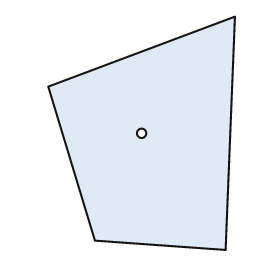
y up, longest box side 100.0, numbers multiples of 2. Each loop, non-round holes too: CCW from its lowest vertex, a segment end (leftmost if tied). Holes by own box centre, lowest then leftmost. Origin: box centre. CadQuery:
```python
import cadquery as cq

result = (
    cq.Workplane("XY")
    .moveTo(36.0, -50.0)
    .lineTo(40.0, 50.0)
    .lineTo(-40.0, 20.0)
    .lineTo(-20.0, -46.0)
    .close()
    .moveTo(0.0, 0.0)
    .circle(2.0)
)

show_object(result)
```